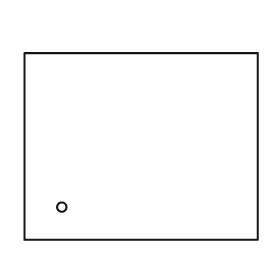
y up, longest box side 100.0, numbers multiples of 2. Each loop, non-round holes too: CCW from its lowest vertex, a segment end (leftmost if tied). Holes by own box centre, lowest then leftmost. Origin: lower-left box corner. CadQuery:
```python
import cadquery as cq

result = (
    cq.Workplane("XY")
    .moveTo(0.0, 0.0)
    .lineTo(100.0, 0.0)
    .lineTo(100.0, 80.0)
    .lineTo(0.0, 80.0)
    .close()
    .moveTo(16.0, 14.0)
    .circle(2.0)
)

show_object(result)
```